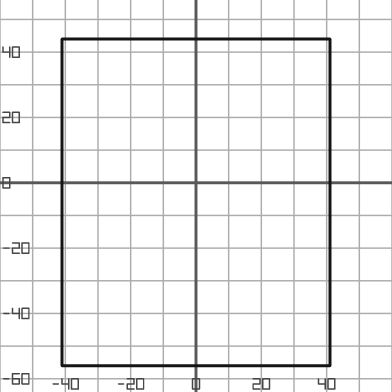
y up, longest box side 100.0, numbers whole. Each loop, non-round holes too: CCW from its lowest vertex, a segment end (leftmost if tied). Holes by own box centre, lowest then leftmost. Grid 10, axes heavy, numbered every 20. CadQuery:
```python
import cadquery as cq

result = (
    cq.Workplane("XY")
    .moveTo(-41.0, -56.0)
    .lineTo(41.0, -56.0)
    .lineTo(41.0, 44.0)
    .lineTo(-41.0, 44.0)
    .close()
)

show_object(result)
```